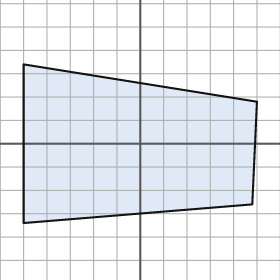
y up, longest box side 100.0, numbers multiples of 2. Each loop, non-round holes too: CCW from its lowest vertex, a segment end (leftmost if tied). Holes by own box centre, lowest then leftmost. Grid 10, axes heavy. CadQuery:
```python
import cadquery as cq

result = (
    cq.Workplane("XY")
    .moveTo(-50.0, -34.0)
    .lineTo(48.0, -26.0)
    .lineTo(50.0, 18.0)
    .lineTo(-50.0, 34.0)
    .close()
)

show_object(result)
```